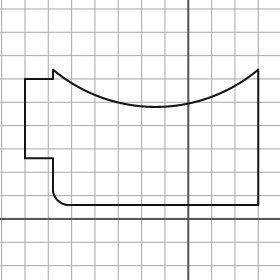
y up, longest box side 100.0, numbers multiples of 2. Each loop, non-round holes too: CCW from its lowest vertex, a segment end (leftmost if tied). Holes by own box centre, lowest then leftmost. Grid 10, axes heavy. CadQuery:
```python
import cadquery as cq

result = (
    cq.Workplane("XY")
    .moveTo(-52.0, 6.0)
    .lineTo(30.0, 6.0)
    .lineTo(30.0, 64.0)
    .threePointArc((-14.0, 48.0), (-58.0, 64.0))
    .lineTo(-58.0, 60.0)
    .lineTo(-70.0, 60.0)
    .lineTo(-70.0, 26.0)
    .lineTo(-58.0, 26.0)
    .lineTo(-58.0, 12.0)
    .threePointArc((-56.0, 8.0), (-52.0, 6.0))
    .close()
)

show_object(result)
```